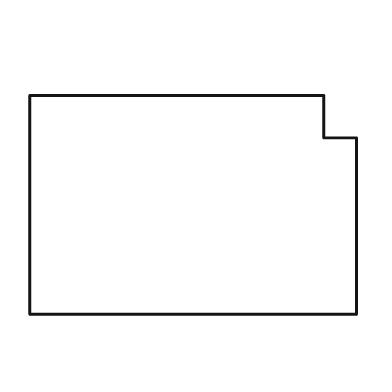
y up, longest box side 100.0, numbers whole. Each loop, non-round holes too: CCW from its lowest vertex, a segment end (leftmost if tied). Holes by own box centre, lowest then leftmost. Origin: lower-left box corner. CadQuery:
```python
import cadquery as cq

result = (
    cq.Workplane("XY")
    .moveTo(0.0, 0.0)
    .lineTo(100.0, 0.0)
    .lineTo(100.0, 54.0)
    .lineTo(90.0, 54.0)
    .lineTo(90.0, 67.0)
    .lineTo(0.0, 67.0)
    .close()
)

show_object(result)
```